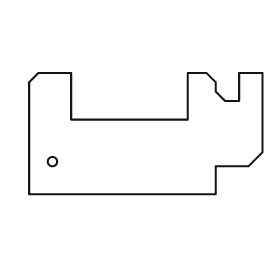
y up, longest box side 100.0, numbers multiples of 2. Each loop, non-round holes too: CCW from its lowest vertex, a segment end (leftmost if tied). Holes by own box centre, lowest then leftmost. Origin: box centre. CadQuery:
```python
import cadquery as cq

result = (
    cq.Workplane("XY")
    .moveTo(-50.0, -26.0)
    .lineTo(30.0, -26.0)
    .lineTo(30.0, -14.0)
    .lineTo(44.0, -14.0)
    .lineTo(50.0, -8.0)
    .lineTo(50.0, 26.0)
    .lineTo(40.0, 26.0)
    .lineTo(40.0, 14.0)
    .lineTo(34.0, 14.0)
    .lineTo(30.0, 18.0)
    .lineTo(30.0, 22.0)
    .lineTo(26.0, 26.0)
    .lineTo(18.0, 26.0)
    .lineTo(18.0, 6.0)
    .lineTo(-32.0, 6.0)
    .lineTo(-32.0, 26.0)
    .lineTo(-46.0, 26.0)
    .lineTo(-50.0, 22.0)
    .close()
    .moveTo(-40.0, -12.0)
    .circle(2.0)
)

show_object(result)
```